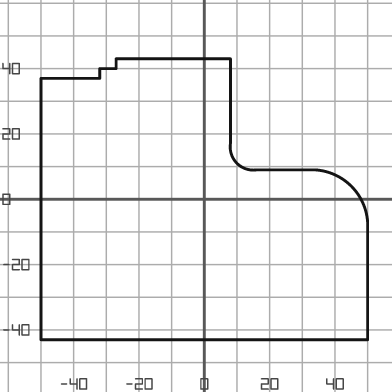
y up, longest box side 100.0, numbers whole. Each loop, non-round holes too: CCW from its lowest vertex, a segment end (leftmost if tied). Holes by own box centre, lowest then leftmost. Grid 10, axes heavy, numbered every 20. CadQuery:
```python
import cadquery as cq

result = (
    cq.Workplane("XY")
    .moveTo(-50.0, -43.0)
    .lineTo(50.0, -43.0)
    .lineTo(50.0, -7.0)
    .threePointArc((45.0, 4.0), (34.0, 9.0))
    .lineTo(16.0, 9.0)
    .threePointArc((10.0, 11.0), (8.0, 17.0))
    .lineTo(8.0, 43.0)
    .lineTo(-27.0, 43.0)
    .lineTo(-27.0, 40.0)
    .lineTo(-32.0, 40.0)
    .lineTo(-32.0, 37.0)
    .lineTo(-50.0, 37.0)
    .close()
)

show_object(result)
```